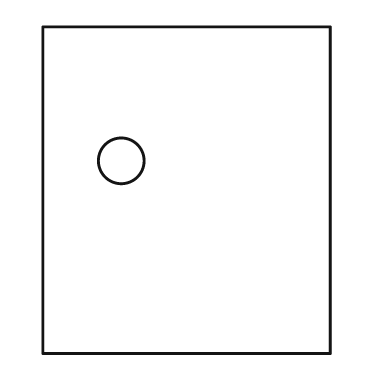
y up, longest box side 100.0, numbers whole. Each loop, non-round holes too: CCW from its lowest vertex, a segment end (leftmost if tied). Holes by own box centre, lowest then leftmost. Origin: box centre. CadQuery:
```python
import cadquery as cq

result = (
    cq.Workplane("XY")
    .moveTo(-44.0, -50.0)
    .lineTo(44.0, -50.0)
    .lineTo(44.0, 50.0)
    .lineTo(-44.0, 50.0)
    .close()
    .moveTo(-20.0, 9.0)
    .circle(7.0)
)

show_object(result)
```